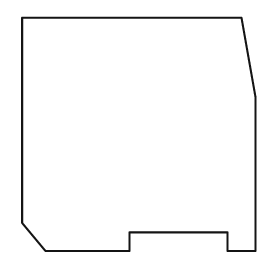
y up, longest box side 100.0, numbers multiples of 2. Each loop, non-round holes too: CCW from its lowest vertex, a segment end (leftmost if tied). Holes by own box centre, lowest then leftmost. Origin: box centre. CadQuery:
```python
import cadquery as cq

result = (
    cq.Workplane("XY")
    .moveTo(-40.0, -50.0)
    .lineTo(-4.0, -50.0)
    .lineTo(-4.0, -42.0)
    .lineTo(38.0, -42.0)
    .lineTo(38.0, -50.0)
    .lineTo(50.0, -50.0)
    .lineTo(50.0, 16.0)
    .lineTo(44.0, 50.0)
    .lineTo(-50.0, 50.0)
    .lineTo(-50.0, -38.0)
    .close()
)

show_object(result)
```